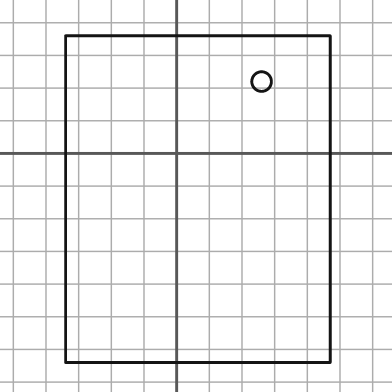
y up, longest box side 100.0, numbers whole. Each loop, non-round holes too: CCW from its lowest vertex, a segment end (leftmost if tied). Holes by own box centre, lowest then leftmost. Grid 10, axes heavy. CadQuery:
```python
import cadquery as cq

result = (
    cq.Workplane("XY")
    .moveTo(-34.0, -64.0)
    .lineTo(47.0, -64.0)
    .lineTo(47.0, 36.0)
    .lineTo(-34.0, 36.0)
    .close()
    .moveTo(26.0, 22.0)
    .circle(3.0)
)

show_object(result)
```